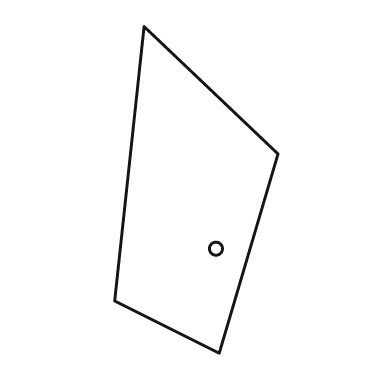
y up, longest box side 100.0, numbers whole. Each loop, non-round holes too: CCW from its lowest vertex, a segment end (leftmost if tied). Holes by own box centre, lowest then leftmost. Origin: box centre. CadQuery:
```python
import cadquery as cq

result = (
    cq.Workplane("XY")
    .moveTo(7.0, -50.0)
    .lineTo(25.0, 11.0)
    .lineTo(-16.0, 50.0)
    .lineTo(-25.0, -34.0)
    .close()
    .moveTo(6.0, -18.0)
    .circle(2.0)
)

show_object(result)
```